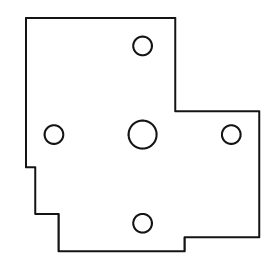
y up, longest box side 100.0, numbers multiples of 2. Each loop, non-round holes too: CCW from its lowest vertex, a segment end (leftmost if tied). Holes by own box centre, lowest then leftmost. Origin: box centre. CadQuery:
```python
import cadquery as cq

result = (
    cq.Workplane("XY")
    .moveTo(-36.0, -50.0)
    .lineTo(18.0, -50.0)
    .lineTo(18.0, -44.0)
    .lineTo(50.0, -44.0)
    .lineTo(50.0, 10.0)
    .lineTo(14.0, 10.0)
    .lineTo(14.0, 50.0)
    .lineTo(-50.0, 50.0)
    .lineTo(-50.0, -14.0)
    .lineTo(-46.0, -14.0)
    .lineTo(-46.0, -34.0)
    .lineTo(-36.0, -34.0)
    .close()
    .moveTo(0.0, -38.0)
    .circle(4.0)
    .moveTo(-38.0, 0.0)
    .circle(4.0)
    .moveTo(0.0, 0.0)
    .circle(6.0)
    .moveTo(38.0, 0.0)
    .circle(4.0)
    .moveTo(0.0, 38.0)
    .circle(4.0)
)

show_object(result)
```